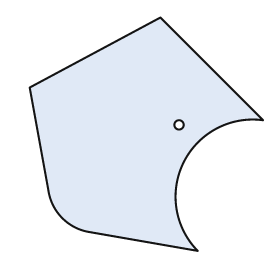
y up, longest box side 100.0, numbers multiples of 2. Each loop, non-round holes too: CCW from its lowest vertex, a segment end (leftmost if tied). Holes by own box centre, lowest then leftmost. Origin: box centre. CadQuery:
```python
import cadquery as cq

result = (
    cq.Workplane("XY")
    .moveTo(22.0, -50.0)
    .threePointArc((16.0, -12.0), (50.0, 6.0))
    .lineTo(6.0, 50.0)
    .lineTo(-50.0, 20.0)
    .lineTo(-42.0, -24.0)
    .threePointArc((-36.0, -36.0), (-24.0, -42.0))
    .close()
    .moveTo(14.0, 4.0)
    .circle(2.0)
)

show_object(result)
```